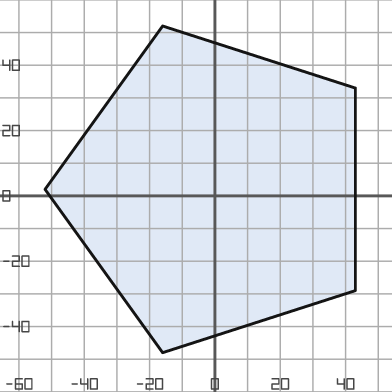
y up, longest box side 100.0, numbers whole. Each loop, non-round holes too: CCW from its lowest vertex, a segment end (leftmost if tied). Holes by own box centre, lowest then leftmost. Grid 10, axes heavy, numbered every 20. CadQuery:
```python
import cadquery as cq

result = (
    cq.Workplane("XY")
    .moveTo(-16.0, -48.0)
    .lineTo(43.0, -29.0)
    .lineTo(43.0, 33.0)
    .lineTo(-16.0, 52.0)
    .lineTo(-52.0, 2.0)
    .close()
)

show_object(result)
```